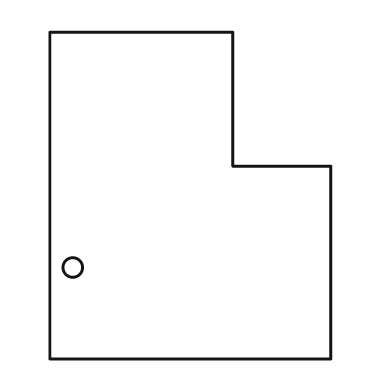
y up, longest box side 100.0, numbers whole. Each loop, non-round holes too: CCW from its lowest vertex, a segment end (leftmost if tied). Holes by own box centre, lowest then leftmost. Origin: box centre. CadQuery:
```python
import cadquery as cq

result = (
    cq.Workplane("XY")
    .moveTo(-43.0, -50.0)
    .lineTo(43.0, -50.0)
    .lineTo(43.0, 9.0)
    .lineTo(13.0, 9.0)
    .lineTo(13.0, 50.0)
    .lineTo(-43.0, 50.0)
    .close()
    .moveTo(-36.0, -22.0)
    .circle(3.0)
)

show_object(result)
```